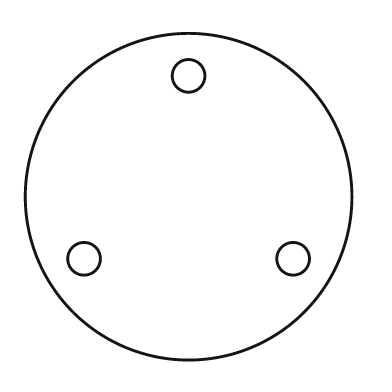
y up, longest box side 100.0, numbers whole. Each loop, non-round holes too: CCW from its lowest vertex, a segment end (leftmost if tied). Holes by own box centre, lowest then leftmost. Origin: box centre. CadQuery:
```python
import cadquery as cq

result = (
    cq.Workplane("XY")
    .moveTo(0.0, 0.0)
    .circle(50.0)
    .moveTo(-32.0, -19.0)
    .circle(5.0)
    .moveTo(32.0, -19.0)
    .circle(5.0)
    .moveTo(0.0, 37.0)
    .circle(5.0)
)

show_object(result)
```